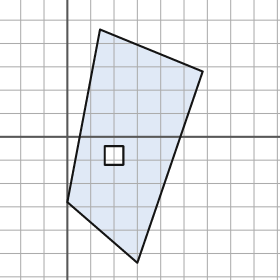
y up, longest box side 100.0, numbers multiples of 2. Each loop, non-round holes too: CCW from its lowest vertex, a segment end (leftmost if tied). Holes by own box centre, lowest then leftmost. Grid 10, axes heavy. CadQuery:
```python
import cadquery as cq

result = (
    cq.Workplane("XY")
    .moveTo(30.0, -54.0)
    .lineTo(58.0, 28.0)
    .lineTo(14.0, 46.0)
    .lineTo(0.0, -28.0)
    .close()
    .moveTo(16.0, -12.0)
    .lineTo(24.0, -12.0)
    .lineTo(24.0, -4.0)
    .lineTo(16.0, -4.0)
    .close()
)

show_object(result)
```